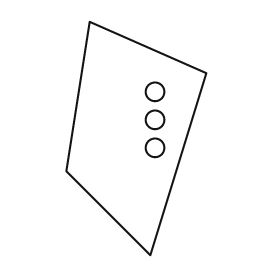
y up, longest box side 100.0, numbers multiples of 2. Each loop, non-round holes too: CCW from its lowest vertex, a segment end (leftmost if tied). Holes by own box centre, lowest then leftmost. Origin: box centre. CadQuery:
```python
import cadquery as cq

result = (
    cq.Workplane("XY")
    .moveTo(6.0, -50.0)
    .lineTo(30.0, 28.0)
    .lineTo(-20.0, 50.0)
    .lineTo(-30.0, -14.0)
    .close()
    .moveTo(8.0, -4.0)
    .circle(4.0)
    .moveTo(8.0, 8.0)
    .circle(4.0)
    .moveTo(8.0, 20.0)
    .circle(4.0)
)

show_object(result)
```